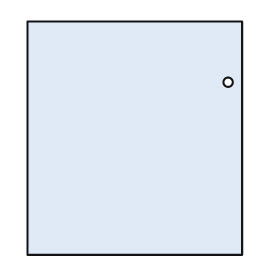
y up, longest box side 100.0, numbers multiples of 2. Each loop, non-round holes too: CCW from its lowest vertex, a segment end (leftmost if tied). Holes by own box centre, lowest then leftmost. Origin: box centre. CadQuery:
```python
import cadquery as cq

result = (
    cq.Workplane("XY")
    .moveTo(-46.0, -50.0)
    .lineTo(46.0, -50.0)
    .lineTo(46.0, 50.0)
    .lineTo(-46.0, 50.0)
    .close()
    .moveTo(40.0, 24.0)
    .circle(2.0)
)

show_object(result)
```